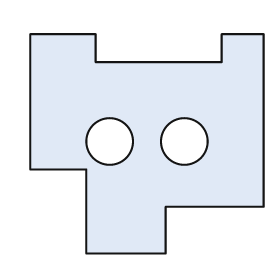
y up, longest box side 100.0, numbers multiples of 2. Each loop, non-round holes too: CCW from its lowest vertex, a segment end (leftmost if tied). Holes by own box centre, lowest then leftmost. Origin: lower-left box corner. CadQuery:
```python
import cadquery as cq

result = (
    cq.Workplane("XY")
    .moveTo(24.0, 0.0)
    .lineTo(58.0, 0.0)
    .lineTo(58.0, 20.0)
    .lineTo(100.0, 20.0)
    .lineTo(100.0, 94.0)
    .lineTo(82.0, 94.0)
    .lineTo(82.0, 82.0)
    .lineTo(28.0, 82.0)
    .lineTo(28.0, 94.0)
    .lineTo(0.0, 94.0)
    .lineTo(0.0, 36.0)
    .lineTo(24.0, 36.0)
    .close()
    .moveTo(34.0, 48.0)
    .circle(10.0)
    .moveTo(66.0, 48.0)
    .circle(10.0)
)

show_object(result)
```